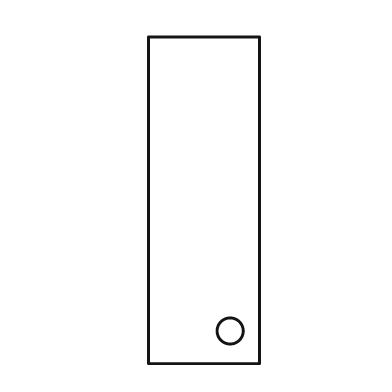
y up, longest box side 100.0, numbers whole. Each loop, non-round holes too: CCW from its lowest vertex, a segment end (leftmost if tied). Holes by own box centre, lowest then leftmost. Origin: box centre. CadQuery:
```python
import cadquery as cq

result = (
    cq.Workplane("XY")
    .moveTo(-17.0, -50.0)
    .lineTo(17.0, -50.0)
    .lineTo(17.0, 50.0)
    .lineTo(-17.0, 50.0)
    .close()
    .moveTo(8.0, -40.0)
    .circle(4.0)
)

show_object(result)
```